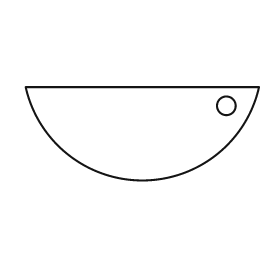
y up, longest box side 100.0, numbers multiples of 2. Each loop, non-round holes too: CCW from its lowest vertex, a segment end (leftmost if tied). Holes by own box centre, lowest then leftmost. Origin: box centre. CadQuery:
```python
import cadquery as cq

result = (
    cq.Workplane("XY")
    .moveTo(-50.0, 20.0)
    .threePointArc((0.0, -20.0), (50.0, 20.0))
    .close()
    .moveTo(36.0, 12.0)
    .circle(4.0)
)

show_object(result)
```